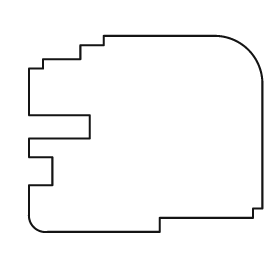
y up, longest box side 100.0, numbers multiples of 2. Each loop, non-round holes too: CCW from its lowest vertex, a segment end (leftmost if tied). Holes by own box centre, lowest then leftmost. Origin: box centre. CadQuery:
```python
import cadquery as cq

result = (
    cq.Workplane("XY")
    .moveTo(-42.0, -42.0)
    .lineTo(6.0, -42.0)
    .lineTo(6.0, -36.0)
    .lineTo(46.0, -36.0)
    .lineTo(46.0, -32.0)
    .lineTo(50.0, -32.0)
    .lineTo(50.0, 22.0)
    .threePointArc((44.0, 36.0), (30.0, 42.0))
    .lineTo(-18.0, 42.0)
    .lineTo(-18.0, 38.0)
    .lineTo(-28.0, 38.0)
    .lineTo(-28.0, 32.0)
    .lineTo(-44.0, 32.0)
    .lineTo(-44.0, 28.0)
    .lineTo(-50.0, 28.0)
    .lineTo(-50.0, 8.0)
    .lineTo(-24.0, 8.0)
    .lineTo(-24.0, -2.0)
    .lineTo(-50.0, -2.0)
    .lineTo(-50.0, -10.0)
    .lineTo(-40.0, -10.0)
    .lineTo(-40.0, -22.0)
    .lineTo(-50.0, -22.0)
    .lineTo(-50.0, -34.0)
    .threePointArc((-48.0, -40.0), (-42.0, -42.0))
    .close()
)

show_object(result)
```